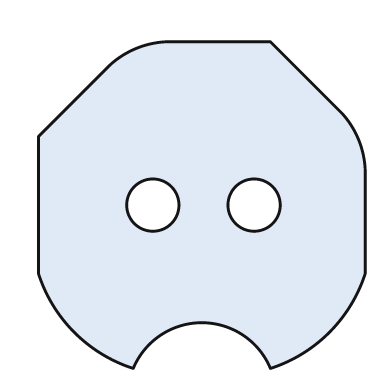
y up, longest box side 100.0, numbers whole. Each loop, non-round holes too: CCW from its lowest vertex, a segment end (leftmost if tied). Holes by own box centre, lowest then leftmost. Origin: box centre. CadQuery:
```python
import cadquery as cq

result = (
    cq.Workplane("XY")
    .moveTo(-21.0, -50.0)
    .threePointArc((0.0, -36.0), (21.0, -50.0))
    .threePointArc((39.0, -39.0), (50.0, -21.0))
    .lineTo(50.0, 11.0)
    .threePointArc((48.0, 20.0), (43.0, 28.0))
    .lineTo(21.0, 50.0)
    .lineTo(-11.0, 50.0)
    .threePointArc((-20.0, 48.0), (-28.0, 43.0))
    .lineTo(-50.0, 21.0)
    .lineTo(-50.0, -21.0)
    .threePointArc((-39.0, -39.0), (-21.0, -50.0))
    .close()
    .moveTo(-15.0, 0.0)
    .circle(8.0)
    .moveTo(16.0, 0.0)
    .circle(8.0)
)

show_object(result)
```